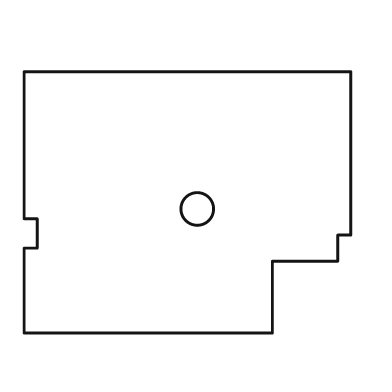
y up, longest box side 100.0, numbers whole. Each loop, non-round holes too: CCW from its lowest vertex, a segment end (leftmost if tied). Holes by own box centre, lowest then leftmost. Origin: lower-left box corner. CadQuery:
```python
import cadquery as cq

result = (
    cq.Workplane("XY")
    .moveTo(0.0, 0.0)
    .lineTo(76.0, 0.0)
    .lineTo(76.0, 22.0)
    .lineTo(96.0, 22.0)
    .lineTo(96.0, 30.0)
    .lineTo(100.0, 30.0)
    .lineTo(100.0, 80.0)
    .lineTo(0.0, 80.0)
    .lineTo(0.0, 35.0)
    .lineTo(4.0, 35.0)
    .lineTo(4.0, 26.0)
    .lineTo(0.0, 26.0)
    .close()
    .moveTo(53.0, 38.0)
    .circle(5.0)
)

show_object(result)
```